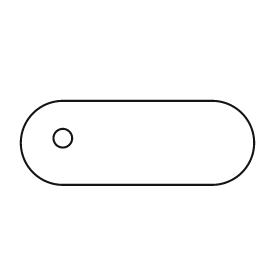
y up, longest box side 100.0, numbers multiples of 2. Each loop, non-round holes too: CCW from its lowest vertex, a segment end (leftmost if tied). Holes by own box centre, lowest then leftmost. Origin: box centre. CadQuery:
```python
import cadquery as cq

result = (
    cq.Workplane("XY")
    .moveTo(-32.0, -18.0)
    .lineTo(32.0, -18.0)
    .threePointArc((50.0, 0.0), (32.0, 18.0))
    .lineTo(-32.0, 18.0)
    .threePointArc((-50.0, 0.0), (-32.0, -18.0))
    .close()
    .moveTo(-32.0, 2.0)
    .circle(4.0)
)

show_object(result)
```